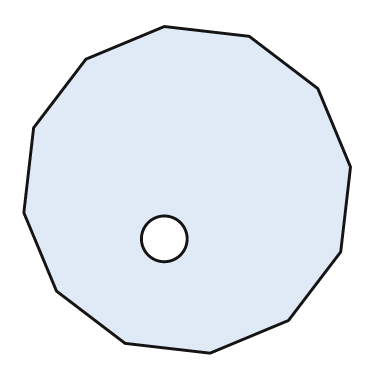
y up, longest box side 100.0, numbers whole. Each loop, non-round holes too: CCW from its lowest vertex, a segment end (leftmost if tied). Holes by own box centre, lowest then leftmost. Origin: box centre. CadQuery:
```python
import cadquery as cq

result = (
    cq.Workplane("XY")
    .moveTo(7.0, -50.0)
    .lineTo(31.0, -40.0)
    .lineTo(47.0, -19.0)
    .lineTo(50.0, 7.0)
    .lineTo(40.0, 31.0)
    .lineTo(19.0, 47.0)
    .lineTo(-7.0, 50.0)
    .lineTo(-31.0, 40.0)
    .lineTo(-47.0, 19.0)
    .lineTo(-50.0, -7.0)
    .lineTo(-40.0, -31.0)
    .lineTo(-19.0, -47.0)
    .close()
    .moveTo(-7.0, -15.0)
    .circle(7.0)
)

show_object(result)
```